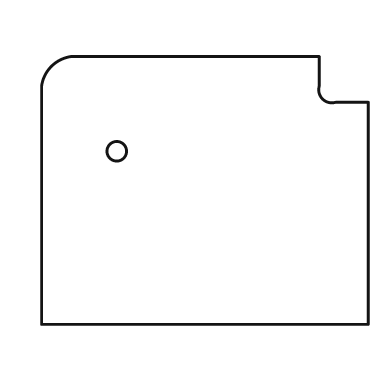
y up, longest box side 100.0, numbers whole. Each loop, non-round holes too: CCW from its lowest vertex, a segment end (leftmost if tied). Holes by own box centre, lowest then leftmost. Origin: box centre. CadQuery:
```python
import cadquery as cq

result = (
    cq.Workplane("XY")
    .moveTo(-50.0, -41.0)
    .lineTo(50.0, -41.0)
    .lineTo(50.0, 27.0)
    .lineTo(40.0, 27.0)
    .threePointArc((36.0, 28.0), (35.0, 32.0))
    .lineTo(35.0, 41.0)
    .lineTo(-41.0, 41.0)
    .threePointArc((-47.0, 38.0), (-50.0, 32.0))
    .close()
    .moveTo(-27.0, 12.0)
    .circle(3.0)
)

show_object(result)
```